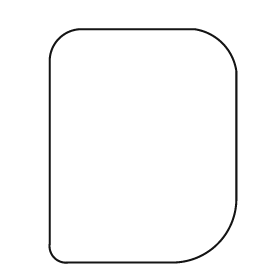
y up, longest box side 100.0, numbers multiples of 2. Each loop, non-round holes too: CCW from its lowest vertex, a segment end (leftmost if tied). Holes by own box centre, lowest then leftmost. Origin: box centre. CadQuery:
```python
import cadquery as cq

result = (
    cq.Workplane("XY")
    .moveTo(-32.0, -50.0)
    .lineTo(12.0, -50.0)
    .threePointArc((32.0, -42.0), (40.0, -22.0))
    .lineTo(40.0, 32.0)
    .threePointArc((34.0, 44.0), (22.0, 50.0))
    .lineTo(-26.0, 50.0)
    .threePointArc((-36.0, 46.0), (-40.0, 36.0))
    .lineTo(-40.0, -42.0)
    .threePointArc((-38.0, -48.0), (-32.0, -50.0))
    .close()
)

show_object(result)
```